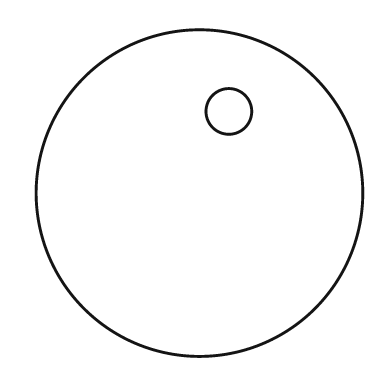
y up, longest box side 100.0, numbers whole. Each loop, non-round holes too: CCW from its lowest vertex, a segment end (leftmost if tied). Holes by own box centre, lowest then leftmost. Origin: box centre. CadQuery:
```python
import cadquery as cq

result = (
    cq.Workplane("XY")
    .moveTo(0.0, 0.0)
    .circle(50.0)
    .moveTo(9.0, 25.0)
    .circle(7.0)
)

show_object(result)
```